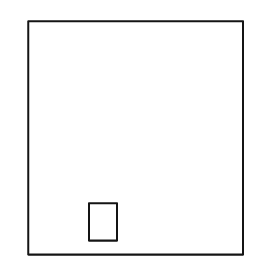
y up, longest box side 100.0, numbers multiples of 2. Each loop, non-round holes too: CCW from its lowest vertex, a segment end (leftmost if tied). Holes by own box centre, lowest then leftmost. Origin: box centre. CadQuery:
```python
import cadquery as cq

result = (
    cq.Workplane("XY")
    .moveTo(-46.0, -50.0)
    .lineTo(46.0, -50.0)
    .lineTo(46.0, 50.0)
    .lineTo(-46.0, 50.0)
    .close()
    .moveTo(-20.0, -44.0)
    .lineTo(-8.0, -44.0)
    .lineTo(-8.0, -28.0)
    .lineTo(-20.0, -28.0)
    .close()
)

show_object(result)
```